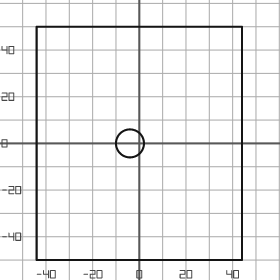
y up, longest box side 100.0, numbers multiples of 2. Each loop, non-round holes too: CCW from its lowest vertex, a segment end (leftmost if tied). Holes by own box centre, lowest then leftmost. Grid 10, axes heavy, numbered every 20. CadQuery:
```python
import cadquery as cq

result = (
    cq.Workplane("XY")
    .moveTo(-44.0, -50.0)
    .lineTo(44.0, -50.0)
    .lineTo(44.0, 50.0)
    .lineTo(-44.0, 50.0)
    .close()
    .moveTo(-4.0, 0.0)
    .circle(6.0)
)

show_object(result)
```